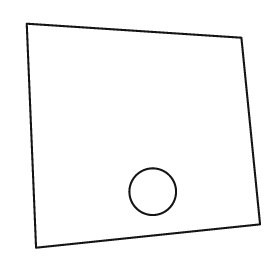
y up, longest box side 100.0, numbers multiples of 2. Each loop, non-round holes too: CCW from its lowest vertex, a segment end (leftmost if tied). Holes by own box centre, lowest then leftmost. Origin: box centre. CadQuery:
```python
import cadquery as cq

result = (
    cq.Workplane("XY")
    .moveTo(-46.0, -48.0)
    .lineTo(50.0, -38.0)
    .lineTo(42.0, 42.0)
    .lineTo(-50.0, 48.0)
    .close()
    .moveTo(4.0, -24.0)
    .circle(10.0)
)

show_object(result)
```